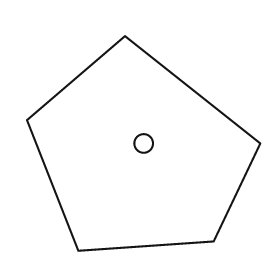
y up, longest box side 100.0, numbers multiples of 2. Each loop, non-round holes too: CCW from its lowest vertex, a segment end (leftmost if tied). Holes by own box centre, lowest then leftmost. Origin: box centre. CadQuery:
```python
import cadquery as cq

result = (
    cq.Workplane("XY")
    .moveTo(-28.0, -46.0)
    .lineTo(30.0, -42.0)
    .lineTo(50.0, 0.0)
    .lineTo(-8.0, 46.0)
    .lineTo(-50.0, 10.0)
    .close()
    .moveTo(0.0, 0.0)
    .circle(4.0)
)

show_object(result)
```